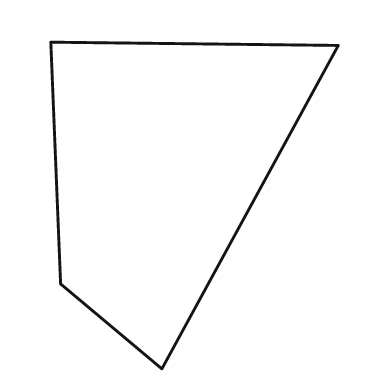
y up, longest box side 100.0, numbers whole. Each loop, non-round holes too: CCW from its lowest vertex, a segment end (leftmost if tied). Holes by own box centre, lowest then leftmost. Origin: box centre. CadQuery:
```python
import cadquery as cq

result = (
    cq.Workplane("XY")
    .moveTo(-10.0, -50.0)
    .lineTo(44.0, 49.0)
    .lineTo(-44.0, 50.0)
    .lineTo(-41.0, -24.0)
    .close()
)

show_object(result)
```